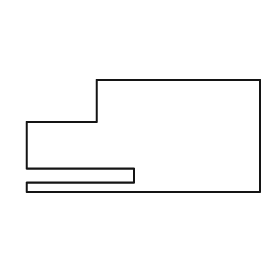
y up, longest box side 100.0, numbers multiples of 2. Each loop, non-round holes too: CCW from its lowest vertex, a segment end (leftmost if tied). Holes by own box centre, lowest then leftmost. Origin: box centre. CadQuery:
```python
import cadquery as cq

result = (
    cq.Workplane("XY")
    .moveTo(-50.0, -24.0)
    .lineTo(50.0, -24.0)
    .lineTo(50.0, 24.0)
    .lineTo(-20.0, 24.0)
    .lineTo(-20.0, 6.0)
    .lineTo(-50.0, 6.0)
    .lineTo(-50.0, -14.0)
    .lineTo(-4.0, -14.0)
    .lineTo(-4.0, -20.0)
    .lineTo(-50.0, -20.0)
    .close()
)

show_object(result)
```